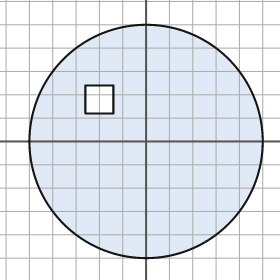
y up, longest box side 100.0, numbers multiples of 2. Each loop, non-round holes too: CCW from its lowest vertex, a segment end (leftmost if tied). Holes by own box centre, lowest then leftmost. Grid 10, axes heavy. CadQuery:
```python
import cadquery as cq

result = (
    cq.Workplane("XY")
    .moveTo(0.0, 0.0)
    .circle(50.0)
    .moveTo(-26.0, 12.0)
    .lineTo(-14.0, 12.0)
    .lineTo(-14.0, 24.0)
    .lineTo(-26.0, 24.0)
    .close()
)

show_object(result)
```